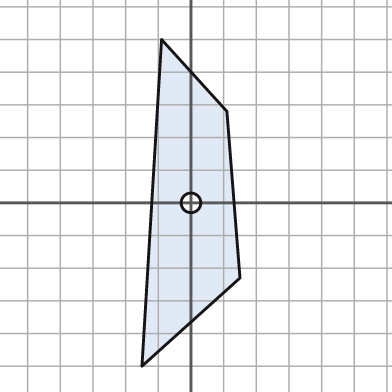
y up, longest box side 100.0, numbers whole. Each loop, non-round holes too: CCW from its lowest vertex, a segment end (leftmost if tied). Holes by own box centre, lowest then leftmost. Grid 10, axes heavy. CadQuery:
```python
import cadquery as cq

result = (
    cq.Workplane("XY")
    .moveTo(-15.0, -50.0)
    .lineTo(15.0, -23.0)
    .lineTo(11.0, 28.0)
    .lineTo(-9.0, 50.0)
    .close()
    .moveTo(0.0, 0.0)
    .circle(3.0)
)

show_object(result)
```